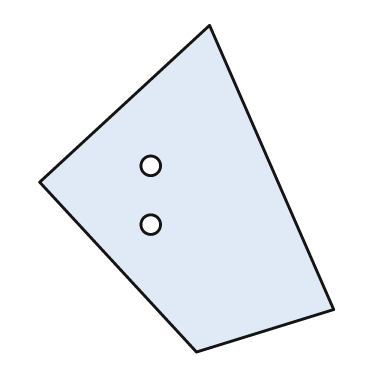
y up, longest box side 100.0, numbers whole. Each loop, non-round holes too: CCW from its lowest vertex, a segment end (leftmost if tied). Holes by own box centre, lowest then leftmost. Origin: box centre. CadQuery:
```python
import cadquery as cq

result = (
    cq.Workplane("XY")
    .moveTo(3.0, -50.0)
    .lineTo(45.0, -37.0)
    .lineTo(7.0, 50.0)
    .lineTo(-45.0, 2.0)
    .close()
    .moveTo(-11.0, -11.0)
    .circle(3.0)
    .moveTo(-11.0, 7.0)
    .circle(3.0)
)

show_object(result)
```